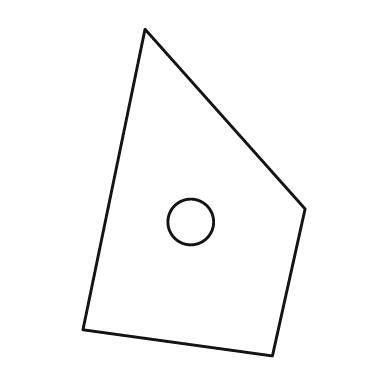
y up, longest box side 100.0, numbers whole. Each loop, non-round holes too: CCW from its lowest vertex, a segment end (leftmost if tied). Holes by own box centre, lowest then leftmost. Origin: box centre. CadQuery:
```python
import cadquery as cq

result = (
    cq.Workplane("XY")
    .moveTo(24.0, -50.0)
    .lineTo(34.0, -5.0)
    .lineTo(-15.0, 50.0)
    .lineTo(-34.0, -42.0)
    .close()
    .moveTo(-1.0, -9.0)
    .circle(7.0)
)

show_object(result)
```